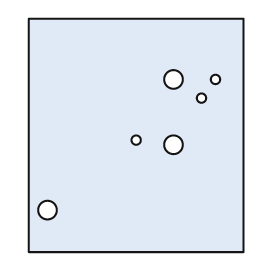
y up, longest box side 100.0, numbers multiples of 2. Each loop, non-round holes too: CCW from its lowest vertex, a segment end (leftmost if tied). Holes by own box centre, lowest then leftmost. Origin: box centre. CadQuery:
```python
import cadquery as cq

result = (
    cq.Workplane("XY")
    .moveTo(-46.0, -50.0)
    .lineTo(46.0, -50.0)
    .lineTo(46.0, 50.0)
    .lineTo(-46.0, 50.0)
    .close()
    .moveTo(-38.0, -32.0)
    .circle(4.0)
    .moveTo(16.0, -4.0)
    .circle(4.0)
    .moveTo(0.0, -2.0)
    .circle(2.0)
    .moveTo(28.0, 16.0)
    .circle(2.0)
    .moveTo(16.0, 24.0)
    .circle(4.0)
    .moveTo(34.0, 24.0)
    .circle(2.0)
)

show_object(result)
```